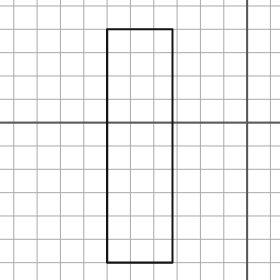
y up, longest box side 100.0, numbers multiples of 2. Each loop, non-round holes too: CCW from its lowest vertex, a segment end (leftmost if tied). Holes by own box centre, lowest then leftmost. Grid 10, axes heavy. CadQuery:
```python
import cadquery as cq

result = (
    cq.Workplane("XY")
    .moveTo(-60.0, -60.0)
    .lineTo(-32.0, -60.0)
    .lineTo(-32.0, 40.0)
    .lineTo(-60.0, 40.0)
    .close()
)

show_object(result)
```